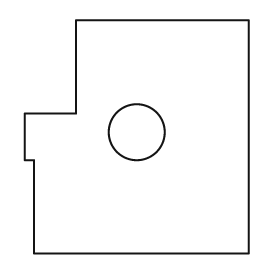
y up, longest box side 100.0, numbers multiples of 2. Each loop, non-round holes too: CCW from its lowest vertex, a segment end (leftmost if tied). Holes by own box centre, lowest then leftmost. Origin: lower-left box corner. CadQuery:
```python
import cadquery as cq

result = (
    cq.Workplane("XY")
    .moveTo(4.0, 0.0)
    .lineTo(96.0, 0.0)
    .lineTo(96.0, 100.0)
    .lineTo(22.0, 100.0)
    .lineTo(22.0, 60.0)
    .lineTo(0.0, 60.0)
    .lineTo(0.0, 40.0)
    .lineTo(4.0, 40.0)
    .close()
    .moveTo(48.0, 52.0)
    .circle(12.0)
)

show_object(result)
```